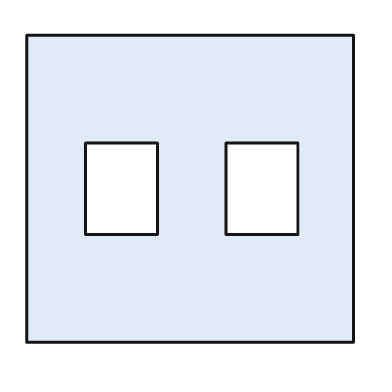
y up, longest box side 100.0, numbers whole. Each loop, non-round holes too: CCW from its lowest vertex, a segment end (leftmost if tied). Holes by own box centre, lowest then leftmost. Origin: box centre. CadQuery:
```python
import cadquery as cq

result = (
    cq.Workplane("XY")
    .moveTo(-50.0, -47.0)
    .lineTo(50.0, -47.0)
    .lineTo(50.0, 47.0)
    .lineTo(-50.0, 47.0)
    .close()
    .moveTo(-32.0, -14.0)
    .lineTo(-10.0, -14.0)
    .lineTo(-10.0, 14.0)
    .lineTo(-32.0, 14.0)
    .close()
    .moveTo(11.0, -14.0)
    .lineTo(33.0, -14.0)
    .lineTo(33.0, 14.0)
    .lineTo(11.0, 14.0)
    .close()
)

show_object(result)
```